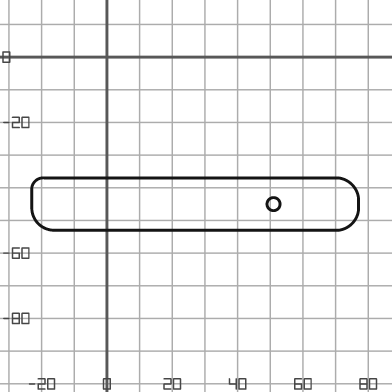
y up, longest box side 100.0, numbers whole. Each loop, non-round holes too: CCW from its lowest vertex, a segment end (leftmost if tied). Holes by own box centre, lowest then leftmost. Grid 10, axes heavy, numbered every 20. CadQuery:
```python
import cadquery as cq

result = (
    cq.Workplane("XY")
    .moveTo(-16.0, -53.0)
    .lineTo(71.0, -53.0)
    .threePointArc((75.0, -51.0), (77.0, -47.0))
    .lineTo(77.0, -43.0)
    .threePointArc((75.0, -39.0), (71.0, -37.0))
    .lineTo(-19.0, -37.0)
    .threePointArc((-22.0, -38.0), (-23.0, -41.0))
    .lineTo(-23.0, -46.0)
    .threePointArc((-21.0, -51.0), (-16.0, -53.0))
    .close()
    .moveTo(51.0, -45.0)
    .circle(2.0)
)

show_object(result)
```